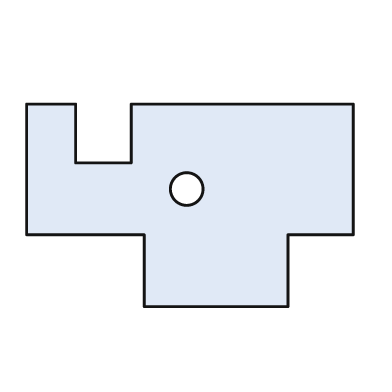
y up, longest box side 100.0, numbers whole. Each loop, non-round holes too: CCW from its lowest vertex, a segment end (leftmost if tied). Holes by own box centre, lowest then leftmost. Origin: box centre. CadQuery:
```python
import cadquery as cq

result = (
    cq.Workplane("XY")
    .moveTo(-14.0, -31.0)
    .lineTo(30.0, -31.0)
    .lineTo(30.0, -9.0)
    .lineTo(50.0, -9.0)
    .lineTo(50.0, 31.0)
    .lineTo(-18.0, 31.0)
    .lineTo(-18.0, 13.0)
    .lineTo(-35.0, 13.0)
    .lineTo(-35.0, 31.0)
    .lineTo(-50.0, 31.0)
    .lineTo(-50.0, -9.0)
    .lineTo(-14.0, -9.0)
    .close()
    .moveTo(-1.0, 5.0)
    .circle(5.0)
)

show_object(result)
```